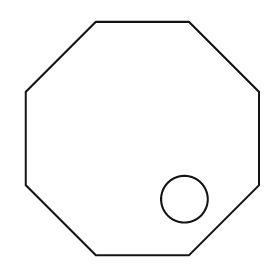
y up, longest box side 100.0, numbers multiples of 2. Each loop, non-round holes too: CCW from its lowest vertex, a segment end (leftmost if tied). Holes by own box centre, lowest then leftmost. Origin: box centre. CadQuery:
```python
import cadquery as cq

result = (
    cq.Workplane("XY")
    .moveTo(-20.0, -50.0)
    .lineTo(20.0, -50.0)
    .lineTo(50.0, -20.0)
    .lineTo(50.0, 20.0)
    .lineTo(20.0, 50.0)
    .lineTo(-20.0, 50.0)
    .lineTo(-50.0, 20.0)
    .lineTo(-50.0, -20.0)
    .close()
    .moveTo(18.0, -26.0)
    .circle(10.0)
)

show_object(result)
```